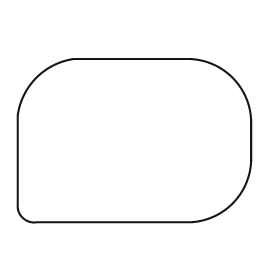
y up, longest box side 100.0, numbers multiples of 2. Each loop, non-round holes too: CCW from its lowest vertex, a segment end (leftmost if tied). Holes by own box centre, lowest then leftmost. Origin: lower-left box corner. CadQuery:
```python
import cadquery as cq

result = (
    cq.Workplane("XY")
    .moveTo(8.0, 0.0)
    .lineTo(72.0, 0.0)
    .threePointArc((92.0, 8.0), (100.0, 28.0))
    .lineTo(100.0, 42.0)
    .threePointArc((92.0, 62.0), (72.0, 70.0))
    .lineTo(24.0, 70.0)
    .threePointArc((8.0, 62.0), (0.0, 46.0))
    .lineTo(0.0, 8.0)
    .threePointArc((2.0, 2.0), (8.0, 0.0))
    .close()
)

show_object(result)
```